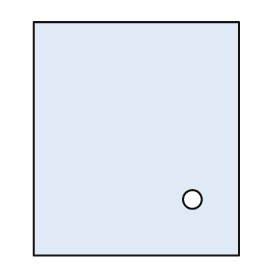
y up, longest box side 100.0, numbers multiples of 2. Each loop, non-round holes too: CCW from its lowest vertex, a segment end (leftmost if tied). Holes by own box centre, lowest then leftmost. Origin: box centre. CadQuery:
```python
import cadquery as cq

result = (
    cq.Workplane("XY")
    .moveTo(-44.0, -50.0)
    .lineTo(44.0, -50.0)
    .lineTo(44.0, 50.0)
    .lineTo(-44.0, 50.0)
    .close()
    .moveTo(24.0, -26.0)
    .circle(4.0)
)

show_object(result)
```